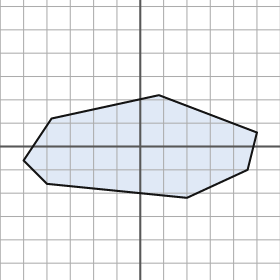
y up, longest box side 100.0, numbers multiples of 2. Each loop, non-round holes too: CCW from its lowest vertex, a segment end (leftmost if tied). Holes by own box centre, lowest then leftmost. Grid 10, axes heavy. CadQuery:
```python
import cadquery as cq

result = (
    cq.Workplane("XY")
    .moveTo(20.0, -22.0)
    .lineTo(46.0, -10.0)
    .lineTo(50.0, 6.0)
    .lineTo(8.0, 22.0)
    .lineTo(-38.0, 12.0)
    .lineTo(-50.0, -6.0)
    .lineTo(-40.0, -16.0)
    .close()
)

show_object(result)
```